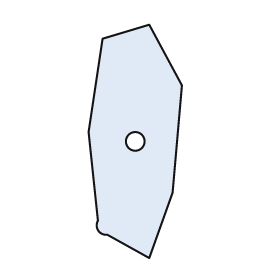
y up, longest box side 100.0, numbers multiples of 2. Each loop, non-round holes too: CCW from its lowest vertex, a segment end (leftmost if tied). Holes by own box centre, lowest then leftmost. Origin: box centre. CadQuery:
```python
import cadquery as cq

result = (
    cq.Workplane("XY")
    .moveTo(6.0, -50.0)
    .lineTo(16.0, -22.0)
    .lineTo(20.0, 24.0)
    .lineTo(6.0, 50.0)
    .lineTo(-14.0, 44.0)
    .lineTo(-20.0, 4.0)
    .lineTo(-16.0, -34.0)
    .threePointArc((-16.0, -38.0), (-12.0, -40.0))
    .close()
    .moveTo(0.0, 0.0)
    .circle(4.0)
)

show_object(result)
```